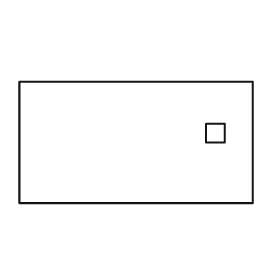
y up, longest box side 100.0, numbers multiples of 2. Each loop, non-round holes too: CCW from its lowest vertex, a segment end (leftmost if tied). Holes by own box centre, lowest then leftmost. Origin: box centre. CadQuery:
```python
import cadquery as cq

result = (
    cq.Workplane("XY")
    .moveTo(-50.0, -26.0)
    .lineTo(50.0, -26.0)
    .lineTo(50.0, 26.0)
    .lineTo(-50.0, 26.0)
    .close()
    .moveTo(30.0, 0.0)
    .lineTo(38.0, 0.0)
    .lineTo(38.0, 8.0)
    .lineTo(30.0, 8.0)
    .close()
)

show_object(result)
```